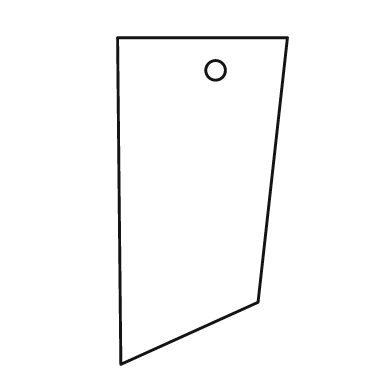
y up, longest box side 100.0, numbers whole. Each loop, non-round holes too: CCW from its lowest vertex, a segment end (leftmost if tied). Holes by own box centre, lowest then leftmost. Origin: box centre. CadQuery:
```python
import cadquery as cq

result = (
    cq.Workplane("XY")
    .moveTo(-25.0, -50.0)
    .lineTo(17.0, -31.0)
    .lineTo(26.0, 50.0)
    .lineTo(-26.0, 50.0)
    .close()
    .moveTo(4.0, 40.0)
    .circle(3.0)
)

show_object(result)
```